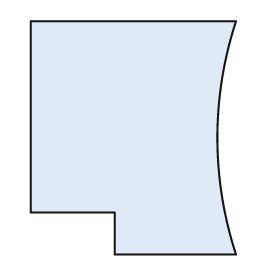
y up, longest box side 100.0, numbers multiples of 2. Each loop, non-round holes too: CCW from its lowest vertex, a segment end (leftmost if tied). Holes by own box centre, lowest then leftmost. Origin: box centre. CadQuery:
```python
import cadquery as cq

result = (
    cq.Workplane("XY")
    .moveTo(-8.0, -50.0)
    .lineTo(44.0, -50.0)
    .threePointArc((36.0, 0.0), (44.0, 50.0))
    .lineTo(-44.0, 50.0)
    .lineTo(-44.0, -32.0)
    .lineTo(-8.0, -32.0)
    .close()
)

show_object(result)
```